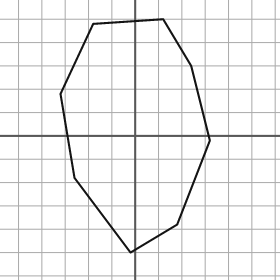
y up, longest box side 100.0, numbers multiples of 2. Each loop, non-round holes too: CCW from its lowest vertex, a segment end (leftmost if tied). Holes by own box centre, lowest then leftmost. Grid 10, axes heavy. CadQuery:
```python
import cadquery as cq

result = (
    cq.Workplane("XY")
    .moveTo(-2.0, -50.0)
    .lineTo(18.0, -38.0)
    .lineTo(32.0, -2.0)
    .lineTo(24.0, 30.0)
    .lineTo(12.0, 50.0)
    .lineTo(-18.0, 48.0)
    .lineTo(-32.0, 18.0)
    .lineTo(-26.0, -18.0)
    .close()
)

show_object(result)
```